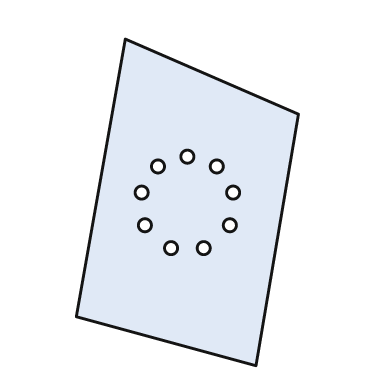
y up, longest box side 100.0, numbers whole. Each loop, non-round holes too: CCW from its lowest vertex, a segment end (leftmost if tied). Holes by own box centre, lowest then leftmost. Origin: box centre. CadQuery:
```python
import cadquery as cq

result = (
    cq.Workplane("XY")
    .moveTo(21.0, -50.0)
    .lineTo(34.0, 27.0)
    .lineTo(-19.0, 50.0)
    .lineTo(-34.0, -35.0)
    .close()
    .moveTo(-5.0, -14.0)
    .circle(2.0)
    .moveTo(5.0, -14.0)
    .circle(2.0)
    .moveTo(-13.0, -7.0)
    .circle(2.0)
    .moveTo(13.0, -7.0)
    .circle(2.0)
    .moveTo(-14.0, 3.0)
    .circle(2.0)
    .moveTo(14.0, 3.0)
    .circle(2.0)
    .moveTo(-9.0, 11.0)
    .circle(2.0)
    .moveTo(9.0, 11.0)
    .circle(2.0)
    .moveTo(0.0, 14.0)
    .circle(2.0)
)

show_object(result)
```